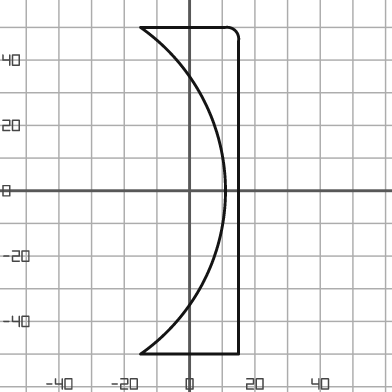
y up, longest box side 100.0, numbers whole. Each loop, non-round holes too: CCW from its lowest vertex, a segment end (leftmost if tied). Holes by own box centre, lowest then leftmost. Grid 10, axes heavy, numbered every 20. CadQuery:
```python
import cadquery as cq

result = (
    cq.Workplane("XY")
    .moveTo(-15.0, -50.0)
    .lineTo(15.0, -50.0)
    .lineTo(15.0, 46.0)
    .threePointArc((14.0, 49.0), (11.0, 50.0))
    .lineTo(-15.0, 50.0)
    .threePointArc((11.0, 0.0), (-15.0, -50.0))
    .close()
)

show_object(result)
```